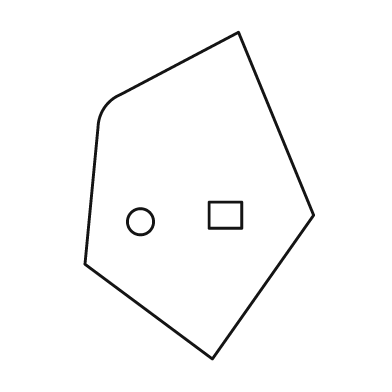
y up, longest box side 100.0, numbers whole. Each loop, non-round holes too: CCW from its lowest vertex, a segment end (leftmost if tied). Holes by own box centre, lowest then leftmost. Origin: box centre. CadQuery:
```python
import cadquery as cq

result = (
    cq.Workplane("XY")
    .moveTo(4.0, -50.0)
    .lineTo(35.0, -6.0)
    .lineTo(12.0, 50.0)
    .lineTo(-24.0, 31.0)
    .threePointArc((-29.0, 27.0), (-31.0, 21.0))
    .lineTo(-35.0, -21.0)
    .close()
    .moveTo(-18.0, -8.0)
    .circle(4.0)
    .moveTo(3.0, -10.0)
    .lineTo(13.0, -10.0)
    .lineTo(13.0, -2.0)
    .lineTo(3.0, -2.0)
    .close()
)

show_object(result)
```